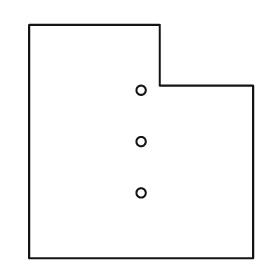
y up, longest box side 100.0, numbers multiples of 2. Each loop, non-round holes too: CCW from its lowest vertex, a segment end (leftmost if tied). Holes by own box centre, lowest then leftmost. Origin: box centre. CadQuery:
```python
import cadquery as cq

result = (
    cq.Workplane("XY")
    .moveTo(-48.0, -50.0)
    .lineTo(48.0, -50.0)
    .lineTo(48.0, 24.0)
    .lineTo(8.0, 24.0)
    .lineTo(8.0, 50.0)
    .lineTo(-48.0, 50.0)
    .close()
    .moveTo(0.0, -22.0)
    .circle(2.0)
    .moveTo(0.0, 0.0)
    .circle(2.0)
    .moveTo(0.0, 22.0)
    .circle(2.0)
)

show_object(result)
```